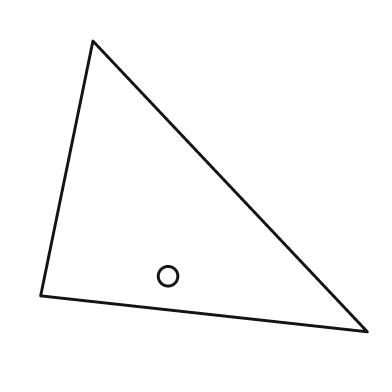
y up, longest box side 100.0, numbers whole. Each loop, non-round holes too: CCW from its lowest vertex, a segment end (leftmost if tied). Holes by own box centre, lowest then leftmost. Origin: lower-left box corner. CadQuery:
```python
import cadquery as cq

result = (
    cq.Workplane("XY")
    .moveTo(100.0, 0.0)
    .lineTo(16.0, 89.0)
    .lineTo(0.0, 11.0)
    .close()
    .moveTo(39.0, 17.0)
    .circle(3.0)
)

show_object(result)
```